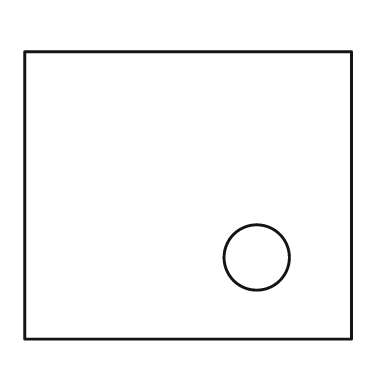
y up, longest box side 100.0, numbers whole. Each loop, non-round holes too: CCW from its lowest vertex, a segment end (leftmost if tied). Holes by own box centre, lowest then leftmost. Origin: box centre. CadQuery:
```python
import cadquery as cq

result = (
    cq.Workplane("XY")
    .moveTo(-50.0, -44.0)
    .lineTo(50.0, -44.0)
    .lineTo(50.0, 44.0)
    .lineTo(-50.0, 44.0)
    .close()
    .moveTo(21.0, -19.0)
    .circle(10.0)
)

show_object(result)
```